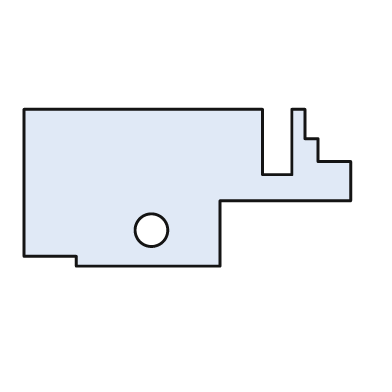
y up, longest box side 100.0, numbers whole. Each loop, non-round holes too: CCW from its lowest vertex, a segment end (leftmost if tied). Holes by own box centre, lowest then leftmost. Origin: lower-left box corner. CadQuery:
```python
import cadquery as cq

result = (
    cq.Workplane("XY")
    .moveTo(16.0, 0.0)
    .lineTo(60.0, 0.0)
    .lineTo(60.0, 20.0)
    .lineTo(100.0, 20.0)
    .lineTo(100.0, 32.0)
    .lineTo(90.0, 32.0)
    .lineTo(90.0, 39.0)
    .lineTo(86.0, 39.0)
    .lineTo(86.0, 48.0)
    .lineTo(82.0, 48.0)
    .lineTo(82.0, 28.0)
    .lineTo(73.0, 28.0)
    .lineTo(73.0, 48.0)
    .lineTo(0.0, 48.0)
    .lineTo(0.0, 3.0)
    .lineTo(16.0, 3.0)
    .close()
    .moveTo(39.0, 11.0)
    .circle(5.0)
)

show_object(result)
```